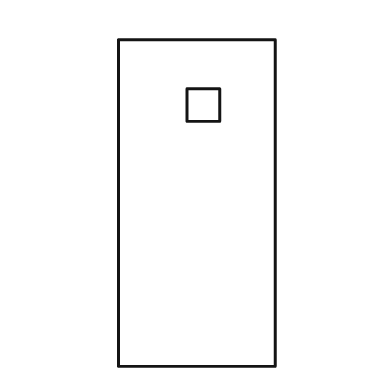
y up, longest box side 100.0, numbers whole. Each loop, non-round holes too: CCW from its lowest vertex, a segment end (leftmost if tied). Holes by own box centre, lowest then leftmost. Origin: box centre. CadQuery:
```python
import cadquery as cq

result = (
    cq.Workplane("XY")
    .moveTo(-24.0, -50.0)
    .lineTo(24.0, -50.0)
    .lineTo(24.0, 50.0)
    .lineTo(-24.0, 50.0)
    .close()
    .moveTo(-3.0, 25.0)
    .lineTo(7.0, 25.0)
    .lineTo(7.0, 35.0)
    .lineTo(-3.0, 35.0)
    .close()
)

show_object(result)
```